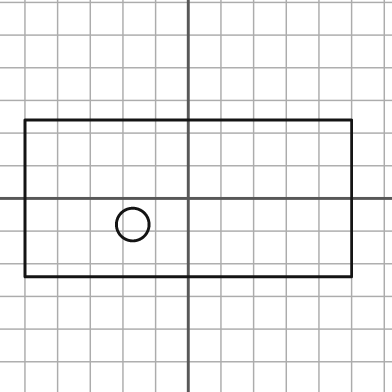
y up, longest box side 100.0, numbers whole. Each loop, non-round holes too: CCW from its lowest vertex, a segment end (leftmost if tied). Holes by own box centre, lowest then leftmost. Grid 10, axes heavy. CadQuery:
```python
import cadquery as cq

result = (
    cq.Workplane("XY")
    .moveTo(-50.0, -24.0)
    .lineTo(50.0, -24.0)
    .lineTo(50.0, 24.0)
    .lineTo(-50.0, 24.0)
    .close()
    .moveTo(-17.0, -8.0)
    .circle(5.0)
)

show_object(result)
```